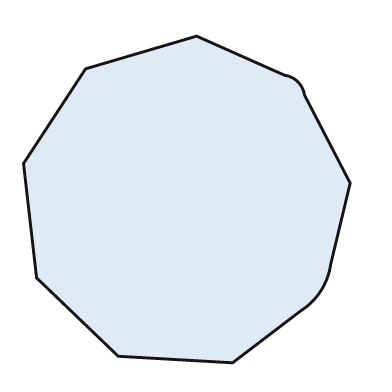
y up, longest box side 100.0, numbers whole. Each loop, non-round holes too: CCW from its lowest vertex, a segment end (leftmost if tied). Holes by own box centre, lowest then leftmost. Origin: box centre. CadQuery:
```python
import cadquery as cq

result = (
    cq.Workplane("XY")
    .moveTo(14.0, -50.0)
    .lineTo(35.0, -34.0)
    .threePointArc((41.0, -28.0), (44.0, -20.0))
    .lineTo(50.0, 5.0)
    .lineTo(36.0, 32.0)
    .threePointArc((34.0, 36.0), (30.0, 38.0))
    .lineTo(3.0, 50.0)
    .lineTo(-31.0, 40.0)
    .lineTo(-50.0, 11.0)
    .lineTo(-46.0, -24.0)
    .lineTo(-21.0, -48.0)
    .close()
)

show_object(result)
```